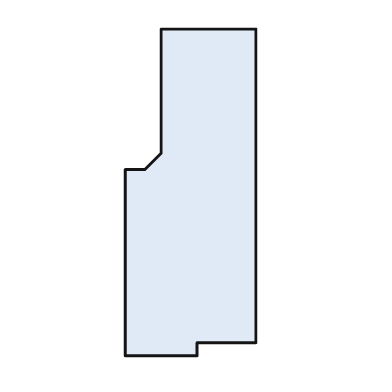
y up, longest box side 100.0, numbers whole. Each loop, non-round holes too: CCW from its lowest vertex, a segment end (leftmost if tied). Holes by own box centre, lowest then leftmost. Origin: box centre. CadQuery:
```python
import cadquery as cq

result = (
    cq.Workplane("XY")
    .moveTo(-20.0, -50.0)
    .lineTo(2.0, -50.0)
    .lineTo(2.0, -46.0)
    .lineTo(20.0, -46.0)
    .lineTo(20.0, 50.0)
    .lineTo(-9.0, 50.0)
    .lineTo(-9.0, 12.0)
    .lineTo(-14.0, 7.0)
    .lineTo(-20.0, 7.0)
    .close()
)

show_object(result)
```